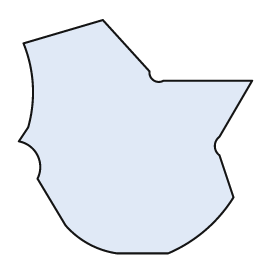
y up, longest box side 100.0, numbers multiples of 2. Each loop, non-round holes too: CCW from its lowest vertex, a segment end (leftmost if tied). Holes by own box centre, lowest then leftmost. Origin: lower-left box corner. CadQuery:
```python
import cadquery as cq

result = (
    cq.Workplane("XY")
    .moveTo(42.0, 0.0)
    .lineTo(64.0, 0.0)
    .threePointArc((80.0, 10.0), (92.0, 24.0))
    .lineTo(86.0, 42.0)
    .threePointArc((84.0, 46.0), (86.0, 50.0))
    .lineTo(100.0, 74.0)
    .lineTo(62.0, 74.0)
    .threePointArc((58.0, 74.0), (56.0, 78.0))
    .lineTo(36.0, 100.0)
    .lineTo(2.0, 90.0)
    .threePointArc((6.0, 72.0), (4.0, 54.0))
    .lineTo(0.0, 48.0)
    .threePointArc((8.0, 42.0), (8.0, 32.0))
    .lineTo(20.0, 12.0)
    .threePointArc((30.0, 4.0), (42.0, 0.0))
    .close()
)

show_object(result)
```